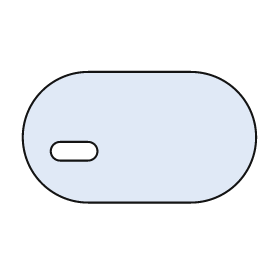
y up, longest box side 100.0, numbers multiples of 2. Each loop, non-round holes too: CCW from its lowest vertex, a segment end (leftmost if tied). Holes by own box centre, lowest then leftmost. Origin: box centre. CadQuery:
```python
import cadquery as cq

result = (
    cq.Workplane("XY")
    .moveTo(-22.0, -28.0)
    .lineTo(22.0, -28.0)
    .threePointArc((50.0, 0.0), (22.0, 28.0))
    .lineTo(-22.0, 28.0)
    .threePointArc((-50.0, 0.0), (-22.0, -28.0))
    .close()
    .moveTo(-34.0, -10.0)
    .lineTo(-22.0, -10.0)
    .threePointArc((-18.0, -6.0), (-22.0, -2.0))
    .lineTo(-34.0, -2.0)
    .threePointArc((-38.0, -6.0), (-34.0, -10.0))
    .close()
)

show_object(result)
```